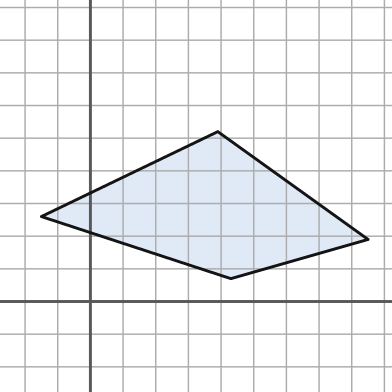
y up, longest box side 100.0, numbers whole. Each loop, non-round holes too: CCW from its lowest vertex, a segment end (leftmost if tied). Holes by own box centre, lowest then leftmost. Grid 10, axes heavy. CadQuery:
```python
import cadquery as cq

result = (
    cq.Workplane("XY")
    .moveTo(43.0, 7.0)
    .lineTo(85.0, 19.0)
    .lineTo(39.0, 52.0)
    .lineTo(-15.0, 26.0)
    .close()
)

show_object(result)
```